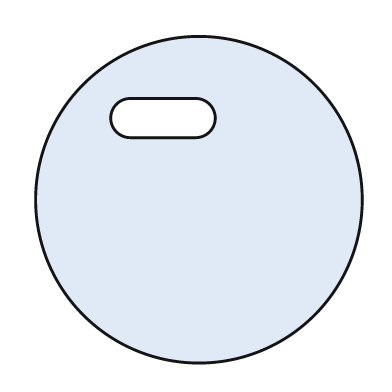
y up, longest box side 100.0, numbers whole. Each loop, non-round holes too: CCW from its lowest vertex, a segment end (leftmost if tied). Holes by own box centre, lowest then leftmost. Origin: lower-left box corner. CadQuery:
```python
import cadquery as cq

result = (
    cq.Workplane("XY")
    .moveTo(50.0, 50.0)
    .circle(50.0)
    .moveTo(29.0, 69.0)
    .lineTo(49.0, 69.0)
    .threePointArc((55.0, 75.0), (49.0, 81.0))
    .lineTo(29.0, 81.0)
    .threePointArc((23.0, 75.0), (29.0, 69.0))
    .close()
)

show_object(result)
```